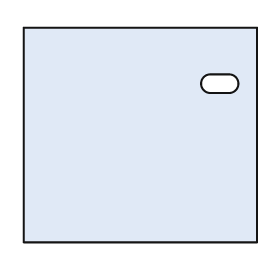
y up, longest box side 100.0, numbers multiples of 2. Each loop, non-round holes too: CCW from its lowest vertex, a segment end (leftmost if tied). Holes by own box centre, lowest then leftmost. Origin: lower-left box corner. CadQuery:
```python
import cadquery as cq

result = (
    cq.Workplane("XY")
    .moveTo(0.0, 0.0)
    .lineTo(100.0, 0.0)
    .lineTo(100.0, 92.0)
    .lineTo(0.0, 92.0)
    .close()
    .moveTo(80.0, 64.0)
    .lineTo(88.0, 64.0)
    .threePointArc((92.0, 68.0), (88.0, 72.0))
    .lineTo(80.0, 72.0)
    .threePointArc((76.0, 68.0), (80.0, 64.0))
    .close()
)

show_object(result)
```